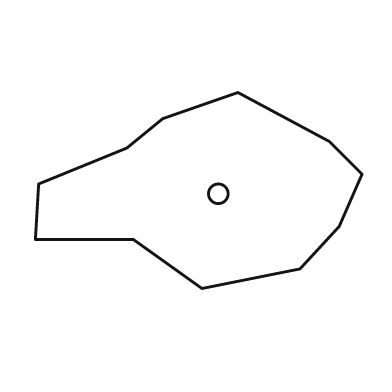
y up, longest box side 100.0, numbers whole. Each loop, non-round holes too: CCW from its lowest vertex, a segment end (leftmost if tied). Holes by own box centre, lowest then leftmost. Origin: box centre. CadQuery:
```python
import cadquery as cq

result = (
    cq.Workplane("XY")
    .moveTo(1.0, -30.0)
    .lineTo(31.0, -24.0)
    .lineTo(43.0, -11.0)
    .lineTo(50.0, 5.0)
    .lineTo(40.0, 15.0)
    .lineTo(12.0, 30.0)
    .lineTo(-11.0, 22.0)
    .lineTo(-22.0, 13.0)
    .lineTo(-49.0, 2.0)
    .lineTo(-50.0, -15.0)
    .lineTo(-20.0, -15.0)
    .close()
    .moveTo(6.0, -1.0)
    .circle(3.0)
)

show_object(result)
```